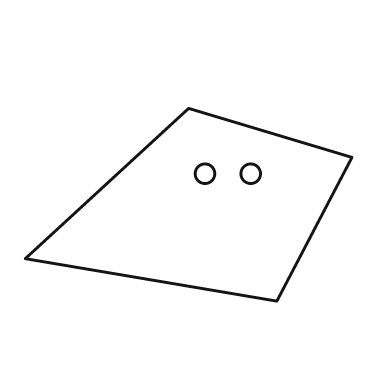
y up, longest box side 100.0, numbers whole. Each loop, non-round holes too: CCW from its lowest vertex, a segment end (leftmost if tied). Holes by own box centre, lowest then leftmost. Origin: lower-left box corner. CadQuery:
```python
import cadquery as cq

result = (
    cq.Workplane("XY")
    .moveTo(77.0, 0.0)
    .lineTo(100.0, 44.0)
    .lineTo(50.0, 59.0)
    .lineTo(0.0, 13.0)
    .close()
    .moveTo(55.0, 39.0)
    .circle(3.0)
    .moveTo(69.0, 39.0)
    .circle(3.0)
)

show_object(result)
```